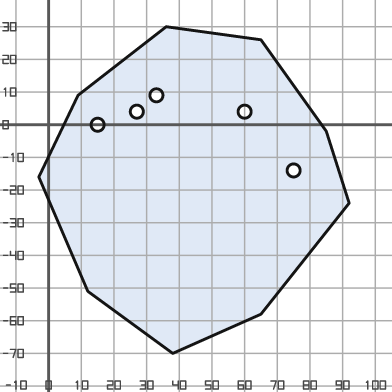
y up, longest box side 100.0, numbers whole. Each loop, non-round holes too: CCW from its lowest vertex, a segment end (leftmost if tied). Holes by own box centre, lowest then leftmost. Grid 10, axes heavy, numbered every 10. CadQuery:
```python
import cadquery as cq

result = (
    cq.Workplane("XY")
    .moveTo(38.0, -70.0)
    .lineTo(65.0, -58.0)
    .lineTo(92.0, -24.0)
    .lineTo(85.0, -2.0)
    .lineTo(65.0, 26.0)
    .lineTo(36.0, 30.0)
    .lineTo(9.0, 9.0)
    .lineTo(-3.0, -16.0)
    .lineTo(12.0, -51.0)
    .close()
    .moveTo(75.0, -14.0)
    .circle(2.0)
    .moveTo(15.0, 0.0)
    .circle(2.0)
    .moveTo(27.0, 4.0)
    .circle(2.0)
    .moveTo(60.0, 4.0)
    .circle(2.0)
    .moveTo(33.0, 9.0)
    .circle(2.0)
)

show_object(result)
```